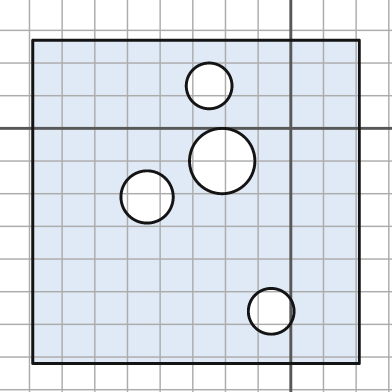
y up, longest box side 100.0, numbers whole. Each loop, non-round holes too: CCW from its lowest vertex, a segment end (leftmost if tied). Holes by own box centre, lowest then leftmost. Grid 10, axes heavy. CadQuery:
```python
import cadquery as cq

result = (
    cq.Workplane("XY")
    .moveTo(-79.0, -72.0)
    .lineTo(21.0, -72.0)
    .lineTo(21.0, 27.0)
    .lineTo(-79.0, 27.0)
    .close()
    .moveTo(-6.0, -56.0)
    .circle(7.0)
    .moveTo(-44.0, -21.0)
    .circle(8.0)
    .moveTo(-21.0, -10.0)
    .circle(10.0)
    .moveTo(-25.0, 13.0)
    .circle(7.0)
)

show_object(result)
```